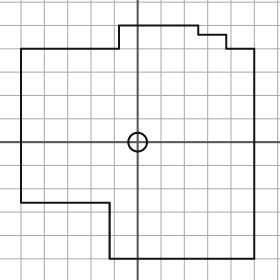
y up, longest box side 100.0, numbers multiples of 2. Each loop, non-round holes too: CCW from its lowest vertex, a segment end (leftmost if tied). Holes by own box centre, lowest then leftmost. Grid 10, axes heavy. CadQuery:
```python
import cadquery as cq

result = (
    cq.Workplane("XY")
    .moveTo(-12.0, -50.0)
    .lineTo(50.0, -50.0)
    .lineTo(50.0, 40.0)
    .lineTo(38.0, 40.0)
    .lineTo(38.0, 46.0)
    .lineTo(26.0, 46.0)
    .lineTo(26.0, 50.0)
    .lineTo(-8.0, 50.0)
    .lineTo(-8.0, 40.0)
    .lineTo(-50.0, 40.0)
    .lineTo(-50.0, -26.0)
    .lineTo(-12.0, -26.0)
    .close()
    .moveTo(0.0, 0.0)
    .circle(4.0)
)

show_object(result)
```